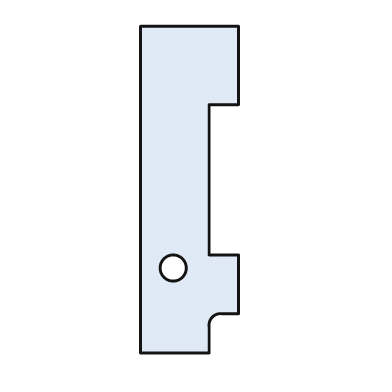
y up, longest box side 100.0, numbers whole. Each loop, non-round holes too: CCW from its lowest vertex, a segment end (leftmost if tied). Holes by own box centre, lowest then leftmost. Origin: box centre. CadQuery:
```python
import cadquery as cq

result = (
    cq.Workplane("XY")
    .moveTo(-15.0, -50.0)
    .lineTo(6.0, -50.0)
    .lineTo(6.0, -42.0)
    .threePointArc((7.0, -39.0), (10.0, -38.0))
    .lineTo(15.0, -38.0)
    .lineTo(15.0, -20.0)
    .lineTo(6.0, -20.0)
    .lineTo(6.0, 26.0)
    .lineTo(15.0, 26.0)
    .lineTo(15.0, 50.0)
    .lineTo(-15.0, 50.0)
    .close()
    .moveTo(-5.0, -24.0)
    .circle(4.0)
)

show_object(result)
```